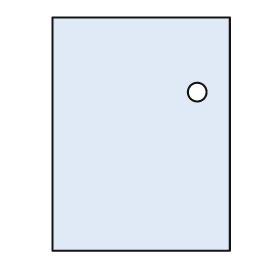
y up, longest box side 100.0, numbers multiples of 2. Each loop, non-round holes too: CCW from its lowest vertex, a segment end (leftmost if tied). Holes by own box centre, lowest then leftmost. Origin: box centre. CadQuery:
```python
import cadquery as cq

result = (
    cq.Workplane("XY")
    .moveTo(-38.0, -50.0)
    .lineTo(38.0, -50.0)
    .lineTo(38.0, 50.0)
    .lineTo(-38.0, 50.0)
    .close()
    .moveTo(24.0, 18.0)
    .circle(4.0)
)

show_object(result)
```